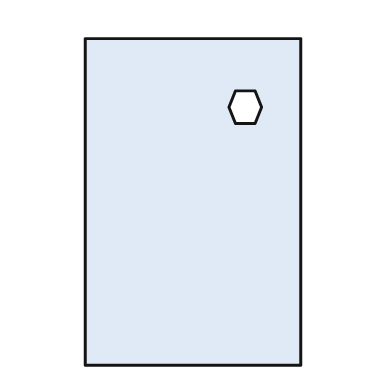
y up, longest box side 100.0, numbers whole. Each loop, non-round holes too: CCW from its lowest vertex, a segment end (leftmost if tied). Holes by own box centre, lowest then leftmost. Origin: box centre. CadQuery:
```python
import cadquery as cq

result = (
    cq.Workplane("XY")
    .moveTo(-33.0, -50.0)
    .lineTo(33.0, -50.0)
    .lineTo(33.0, 50.0)
    .lineTo(-33.0, 50.0)
    .close()
    .moveTo(13.0, 24.0)
    .lineTo(19.0, 24.0)
    .lineTo(21.0, 29.0)
    .lineTo(19.0, 34.0)
    .lineTo(13.0, 34.0)
    .lineTo(11.0, 29.0)
    .close()
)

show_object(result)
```